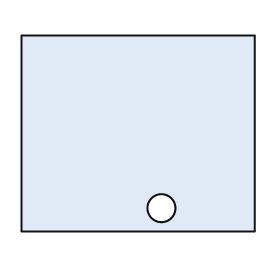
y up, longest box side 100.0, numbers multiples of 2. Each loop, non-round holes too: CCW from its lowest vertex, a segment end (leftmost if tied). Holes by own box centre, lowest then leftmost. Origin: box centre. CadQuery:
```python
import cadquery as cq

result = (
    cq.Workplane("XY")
    .moveTo(-50.0, -42.0)
    .lineTo(50.0, -42.0)
    .lineTo(50.0, 42.0)
    .lineTo(-50.0, 42.0)
    .close()
    .moveTo(10.0, -32.0)
    .circle(6.0)
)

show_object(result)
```